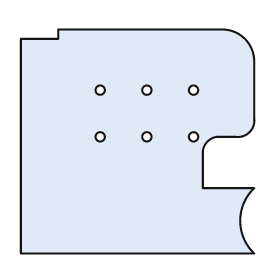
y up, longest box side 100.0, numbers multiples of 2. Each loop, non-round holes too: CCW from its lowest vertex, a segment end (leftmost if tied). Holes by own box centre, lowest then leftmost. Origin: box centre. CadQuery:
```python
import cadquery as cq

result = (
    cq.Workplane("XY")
    .moveTo(-50.0, -48.0)
    .lineTo(50.0, -48.0)
    .threePointArc((44.0, -34.0), (50.0, -20.0))
    .lineTo(28.0, -20.0)
    .lineTo(28.0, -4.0)
    .threePointArc((30.0, 0.0), (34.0, 2.0))
    .lineTo(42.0, 2.0)
    .threePointArc((48.0, 4.0), (50.0, 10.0))
    .lineTo(50.0, 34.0)
    .threePointArc((46.0, 44.0), (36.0, 48.0))
    .lineTo(-34.0, 48.0)
    .lineTo(-34.0, 44.0)
    .lineTo(-50.0, 44.0)
    .close()
    .moveTo(-16.0, 2.0)
    .circle(2.0)
    .moveTo(4.0, 2.0)
    .circle(2.0)
    .moveTo(24.0, 2.0)
    .circle(2.0)
    .moveTo(-16.0, 22.0)
    .circle(2.0)
    .moveTo(4.0, 22.0)
    .circle(2.0)
    .moveTo(24.0, 22.0)
    .circle(2.0)
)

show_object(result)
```